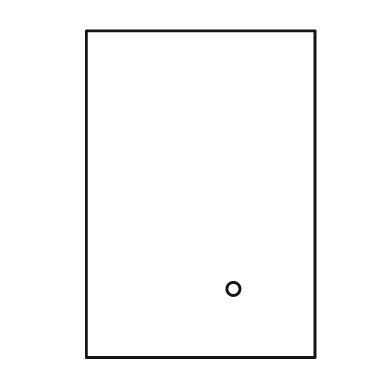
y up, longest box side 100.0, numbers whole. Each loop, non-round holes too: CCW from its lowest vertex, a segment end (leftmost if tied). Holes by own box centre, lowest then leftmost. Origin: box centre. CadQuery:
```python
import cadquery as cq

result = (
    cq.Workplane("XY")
    .moveTo(-35.0, -50.0)
    .lineTo(35.0, -50.0)
    .lineTo(35.0, 50.0)
    .lineTo(-35.0, 50.0)
    .close()
    .moveTo(10.0, -29.0)
    .circle(2.0)
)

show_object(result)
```